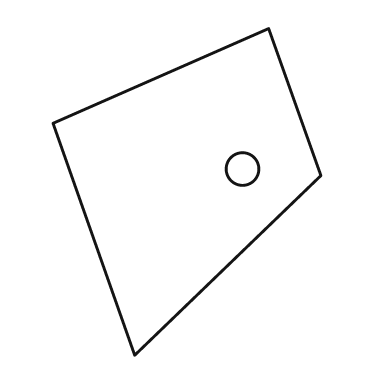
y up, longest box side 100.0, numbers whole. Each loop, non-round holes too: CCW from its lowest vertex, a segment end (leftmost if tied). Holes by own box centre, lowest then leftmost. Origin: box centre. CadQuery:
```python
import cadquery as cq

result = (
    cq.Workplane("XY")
    .moveTo(-16.0, -50.0)
    .lineTo(41.0, 5.0)
    .lineTo(25.0, 50.0)
    .lineTo(-41.0, 21.0)
    .close()
    .moveTo(17.0, 7.0)
    .circle(5.0)
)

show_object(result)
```